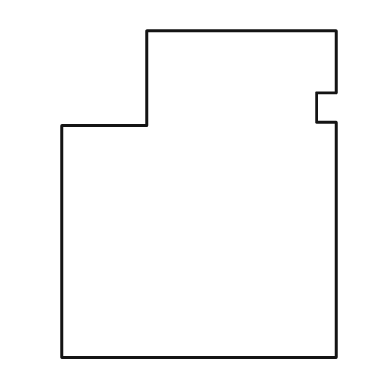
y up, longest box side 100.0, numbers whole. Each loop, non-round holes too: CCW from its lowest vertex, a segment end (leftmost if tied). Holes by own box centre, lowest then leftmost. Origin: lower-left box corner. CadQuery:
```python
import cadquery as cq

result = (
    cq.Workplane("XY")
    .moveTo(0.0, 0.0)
    .lineTo(84.0, 0.0)
    .lineTo(84.0, 72.0)
    .lineTo(78.0, 72.0)
    .lineTo(78.0, 81.0)
    .lineTo(84.0, 81.0)
    .lineTo(84.0, 100.0)
    .lineTo(26.0, 100.0)
    .lineTo(26.0, 71.0)
    .lineTo(0.0, 71.0)
    .close()
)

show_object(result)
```